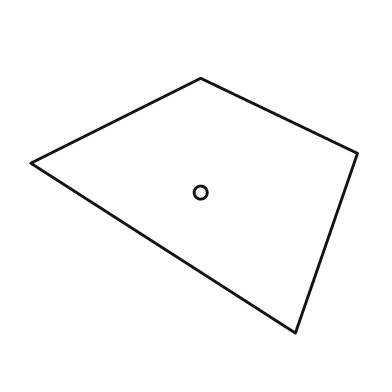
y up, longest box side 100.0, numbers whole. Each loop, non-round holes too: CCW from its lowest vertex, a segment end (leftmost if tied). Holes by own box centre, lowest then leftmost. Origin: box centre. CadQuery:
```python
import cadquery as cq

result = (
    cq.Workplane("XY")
    .moveTo(31.0, -39.0)
    .lineTo(50.0, 16.0)
    .lineTo(2.0, 39.0)
    .lineTo(-50.0, 13.0)
    .close()
    .moveTo(2.0, 4.0)
    .circle(2.0)
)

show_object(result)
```